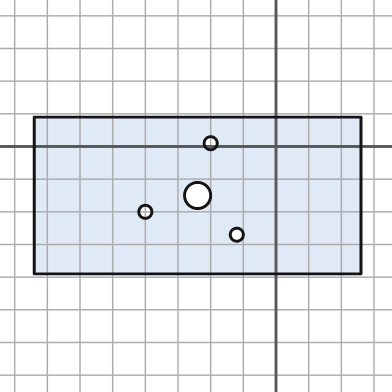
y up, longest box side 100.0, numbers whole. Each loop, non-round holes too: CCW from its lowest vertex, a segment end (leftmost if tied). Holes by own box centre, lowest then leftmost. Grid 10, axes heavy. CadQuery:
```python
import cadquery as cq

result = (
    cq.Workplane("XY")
    .moveTo(-74.0, -39.0)
    .lineTo(26.0, -39.0)
    .lineTo(26.0, 9.0)
    .lineTo(-74.0, 9.0)
    .close()
    .moveTo(-12.0, -27.0)
    .circle(2.0)
    .moveTo(-40.0, -20.0)
    .circle(2.0)
    .moveTo(-24.0, -15.0)
    .circle(4.0)
    .moveTo(-20.0, 1.0)
    .circle(2.0)
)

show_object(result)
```